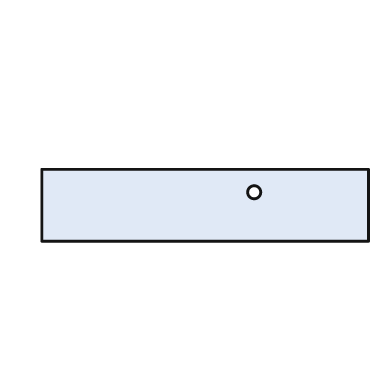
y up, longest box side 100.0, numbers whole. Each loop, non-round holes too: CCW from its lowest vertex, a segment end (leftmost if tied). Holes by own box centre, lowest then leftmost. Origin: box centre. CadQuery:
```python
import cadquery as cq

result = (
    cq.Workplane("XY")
    .moveTo(-50.0, -11.0)
    .lineTo(50.0, -11.0)
    .lineTo(50.0, 11.0)
    .lineTo(-50.0, 11.0)
    .close()
    .moveTo(15.0, 4.0)
    .circle(2.0)
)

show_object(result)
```